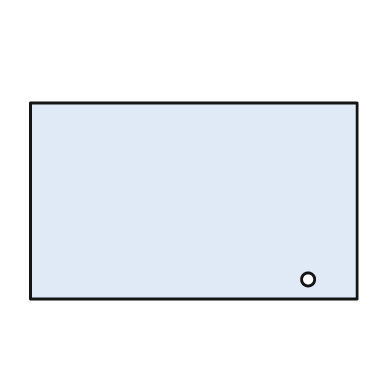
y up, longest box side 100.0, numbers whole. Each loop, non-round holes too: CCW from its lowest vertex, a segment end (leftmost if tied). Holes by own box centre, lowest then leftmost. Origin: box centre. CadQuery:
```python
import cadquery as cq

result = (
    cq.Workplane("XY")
    .moveTo(-50.0, -30.0)
    .lineTo(50.0, -30.0)
    .lineTo(50.0, 30.0)
    .lineTo(-50.0, 30.0)
    .close()
    .moveTo(35.0, -24.0)
    .circle(2.0)
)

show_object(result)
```